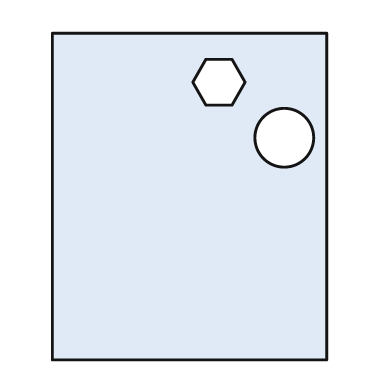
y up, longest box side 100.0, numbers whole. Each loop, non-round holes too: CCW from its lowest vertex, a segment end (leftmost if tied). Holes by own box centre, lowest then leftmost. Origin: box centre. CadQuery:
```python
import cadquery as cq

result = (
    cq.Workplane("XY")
    .moveTo(-42.0, -50.0)
    .lineTo(42.0, -50.0)
    .lineTo(42.0, 50.0)
    .lineTo(-42.0, 50.0)
    .close()
    .moveTo(29.0, 18.0)
    .circle(9.0)
    .moveTo(5.0, 28.0)
    .lineTo(13.0, 28.0)
    .lineTo(17.0, 35.0)
    .lineTo(13.0, 42.0)
    .lineTo(5.0, 42.0)
    .lineTo(1.0, 35.0)
    .close()
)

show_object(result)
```